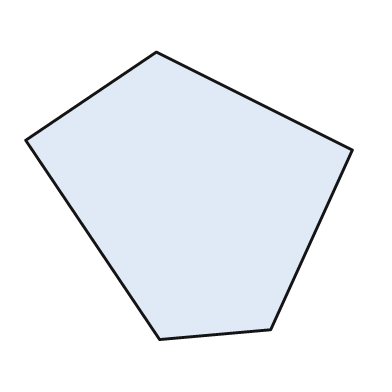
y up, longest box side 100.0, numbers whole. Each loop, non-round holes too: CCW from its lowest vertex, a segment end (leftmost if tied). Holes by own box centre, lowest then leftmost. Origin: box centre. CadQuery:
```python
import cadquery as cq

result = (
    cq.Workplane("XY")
    .moveTo(-9.0, -44.0)
    .lineTo(25.0, -41.0)
    .lineTo(50.0, 14.0)
    .lineTo(-10.0, 44.0)
    .lineTo(-50.0, 17.0)
    .close()
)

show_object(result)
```